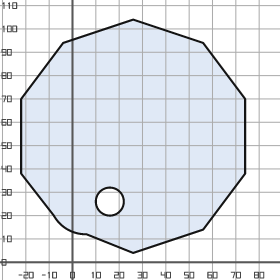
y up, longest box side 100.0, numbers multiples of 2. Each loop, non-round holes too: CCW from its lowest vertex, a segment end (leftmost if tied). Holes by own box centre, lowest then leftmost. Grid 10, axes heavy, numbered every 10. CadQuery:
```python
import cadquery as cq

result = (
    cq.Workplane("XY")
    .moveTo(26.0, 4.0)
    .lineTo(56.0, 14.0)
    .lineTo(74.0, 38.0)
    .lineTo(74.0, 70.0)
    .lineTo(56.0, 94.0)
    .lineTo(26.0, 104.0)
    .lineTo(-4.0, 94.0)
    .lineTo(-22.0, 70.0)
    .lineTo(-22.0, 38.0)
    .lineTo(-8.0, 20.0)
    .threePointArc((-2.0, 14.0), (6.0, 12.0))
    .close()
    .moveTo(16.0, 26.0)
    .circle(6.0)
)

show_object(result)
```